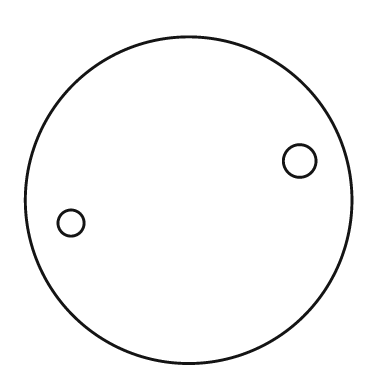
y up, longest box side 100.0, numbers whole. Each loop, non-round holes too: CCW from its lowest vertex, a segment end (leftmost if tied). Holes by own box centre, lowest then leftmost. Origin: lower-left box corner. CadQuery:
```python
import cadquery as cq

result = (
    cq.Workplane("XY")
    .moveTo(50.0, 50.0)
    .circle(50.0)
    .moveTo(14.0, 43.0)
    .circle(4.0)
    .moveTo(84.0, 62.0)
    .circle(5.0)
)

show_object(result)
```